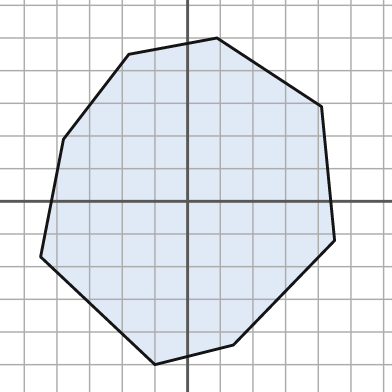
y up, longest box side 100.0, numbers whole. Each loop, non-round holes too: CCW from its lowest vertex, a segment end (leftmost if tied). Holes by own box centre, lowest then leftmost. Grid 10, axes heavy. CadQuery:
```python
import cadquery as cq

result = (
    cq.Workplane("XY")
    .moveTo(-10.0, -50.0)
    .lineTo(14.0, -44.0)
    .lineTo(45.0, -12.0)
    .lineTo(41.0, 29.0)
    .lineTo(9.0, 50.0)
    .lineTo(-18.0, 45.0)
    .lineTo(-38.0, 19.0)
    .lineTo(-45.0, -17.0)
    .close()
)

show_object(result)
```